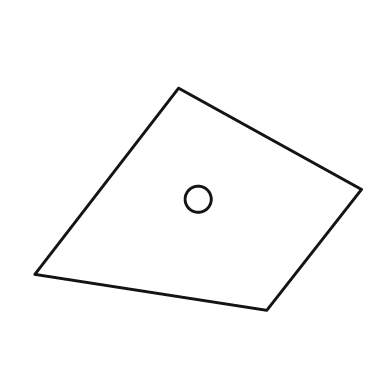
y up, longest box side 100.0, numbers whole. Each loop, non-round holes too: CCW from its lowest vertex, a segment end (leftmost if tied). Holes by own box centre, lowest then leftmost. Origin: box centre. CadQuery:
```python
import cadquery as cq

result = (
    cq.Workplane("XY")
    .moveTo(21.0, -34.0)
    .lineTo(50.0, 3.0)
    .lineTo(-6.0, 34.0)
    .lineTo(-50.0, -23.0)
    .close()
    .moveTo(0.0, 0.0)
    .circle(4.0)
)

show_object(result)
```